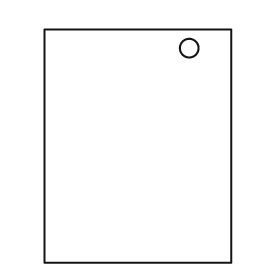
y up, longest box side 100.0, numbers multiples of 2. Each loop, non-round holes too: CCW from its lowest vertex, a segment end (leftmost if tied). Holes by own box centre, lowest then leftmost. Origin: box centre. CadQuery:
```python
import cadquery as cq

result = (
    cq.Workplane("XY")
    .moveTo(-40.0, -50.0)
    .lineTo(40.0, -50.0)
    .lineTo(40.0, 50.0)
    .lineTo(-40.0, 50.0)
    .close()
    .moveTo(22.0, 42.0)
    .circle(4.0)
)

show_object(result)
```